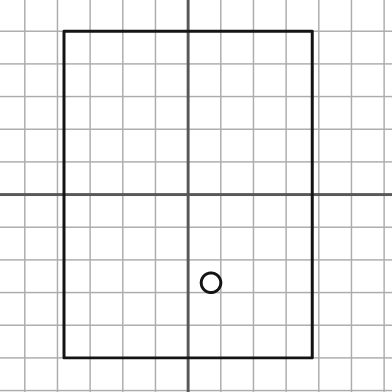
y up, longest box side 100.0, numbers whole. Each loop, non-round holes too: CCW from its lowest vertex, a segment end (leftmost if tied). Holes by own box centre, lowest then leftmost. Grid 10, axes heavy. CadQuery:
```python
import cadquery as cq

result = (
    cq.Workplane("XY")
    .moveTo(-38.0, -50.0)
    .lineTo(38.0, -50.0)
    .lineTo(38.0, 50.0)
    .lineTo(-38.0, 50.0)
    .close()
    .moveTo(7.0, -27.0)
    .circle(3.0)
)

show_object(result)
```